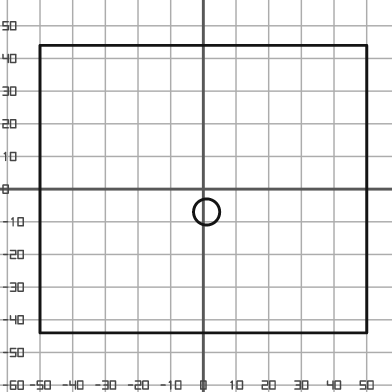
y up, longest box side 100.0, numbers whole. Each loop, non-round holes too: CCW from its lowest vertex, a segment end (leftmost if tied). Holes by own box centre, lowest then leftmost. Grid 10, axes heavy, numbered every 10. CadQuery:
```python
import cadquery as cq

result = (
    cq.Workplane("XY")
    .moveTo(-50.0, -44.0)
    .lineTo(50.0, -44.0)
    .lineTo(50.0, 44.0)
    .lineTo(-50.0, 44.0)
    .close()
    .moveTo(1.0, -7.0)
    .circle(4.0)
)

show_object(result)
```